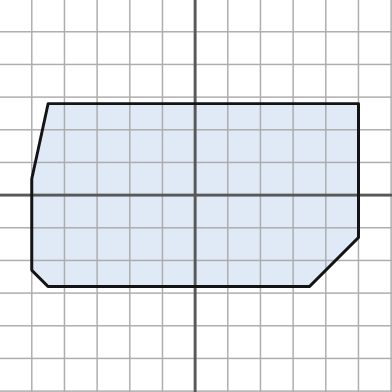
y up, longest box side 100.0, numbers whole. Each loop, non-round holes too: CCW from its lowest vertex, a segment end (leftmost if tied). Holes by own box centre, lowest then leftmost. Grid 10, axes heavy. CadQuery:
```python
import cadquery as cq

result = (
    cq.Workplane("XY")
    .moveTo(-45.0, -28.0)
    .lineTo(35.0, -28.0)
    .lineTo(50.0, -13.0)
    .lineTo(50.0, 28.0)
    .lineTo(-45.0, 28.0)
    .lineTo(-50.0, 5.0)
    .lineTo(-50.0, -23.0)
    .close()
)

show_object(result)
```